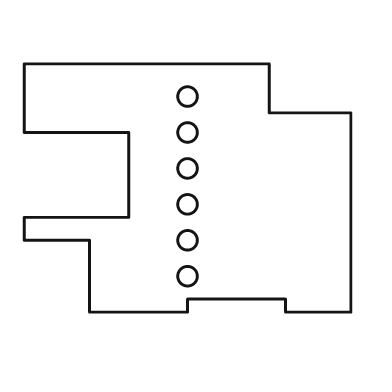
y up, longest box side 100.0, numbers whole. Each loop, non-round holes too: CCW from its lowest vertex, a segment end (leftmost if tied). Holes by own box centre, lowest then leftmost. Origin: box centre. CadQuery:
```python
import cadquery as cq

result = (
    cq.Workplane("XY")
    .moveTo(-30.0, -38.0)
    .lineTo(0.0, -38.0)
    .lineTo(0.0, -34.0)
    .lineTo(30.0, -34.0)
    .lineTo(30.0, -38.0)
    .lineTo(50.0, -38.0)
    .lineTo(50.0, 23.0)
    .lineTo(25.0, 23.0)
    .lineTo(25.0, 38.0)
    .lineTo(-50.0, 38.0)
    .lineTo(-50.0, 17.0)
    .lineTo(-18.0, 17.0)
    .lineTo(-18.0, -9.0)
    .lineTo(-50.0, -9.0)
    .lineTo(-50.0, -16.0)
    .lineTo(-30.0, -16.0)
    .close()
    .moveTo(0.0, -27.0)
    .circle(3.0)
    .moveTo(0.0, -16.0)
    .circle(3.0)
    .moveTo(0.0, -5.0)
    .circle(3.0)
    .moveTo(0.0, 6.0)
    .circle(3.0)
    .moveTo(0.0, 17.0)
    .circle(3.0)
    .moveTo(0.0, 28.0)
    .circle(3.0)
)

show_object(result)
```